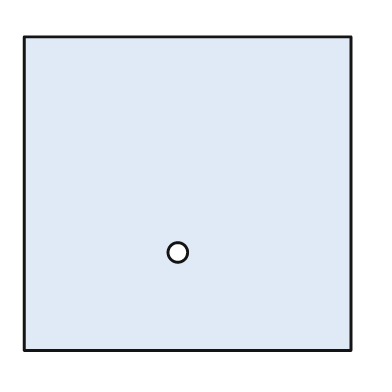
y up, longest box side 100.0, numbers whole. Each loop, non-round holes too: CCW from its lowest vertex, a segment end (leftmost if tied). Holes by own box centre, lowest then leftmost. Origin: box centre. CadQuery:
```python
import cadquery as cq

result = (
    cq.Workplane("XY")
    .moveTo(-50.0, -48.0)
    .lineTo(50.0, -48.0)
    .lineTo(50.0, 48.0)
    .lineTo(-50.0, 48.0)
    .close()
    .moveTo(-3.0, -18.0)
    .circle(3.0)
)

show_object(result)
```